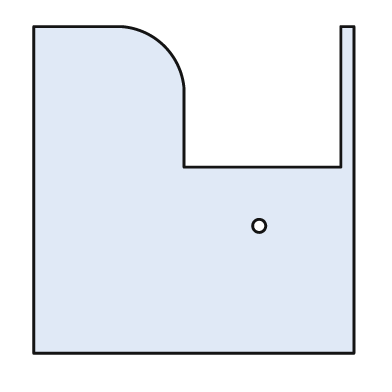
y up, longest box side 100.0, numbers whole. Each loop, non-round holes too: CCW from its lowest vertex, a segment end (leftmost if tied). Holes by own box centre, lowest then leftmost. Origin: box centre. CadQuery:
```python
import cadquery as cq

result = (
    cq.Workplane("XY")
    .moveTo(-49.0, -50.0)
    .lineTo(49.0, -50.0)
    .lineTo(49.0, 50.0)
    .lineTo(45.0, 50.0)
    .lineTo(45.0, 7.0)
    .lineTo(-3.0, 7.0)
    .lineTo(-3.0, 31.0)
    .threePointArc((-9.0, 44.0), (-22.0, 50.0))
    .lineTo(-49.0, 50.0)
    .close()
    .moveTo(20.0, -11.0)
    .circle(2.0)
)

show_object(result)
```